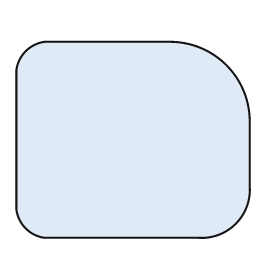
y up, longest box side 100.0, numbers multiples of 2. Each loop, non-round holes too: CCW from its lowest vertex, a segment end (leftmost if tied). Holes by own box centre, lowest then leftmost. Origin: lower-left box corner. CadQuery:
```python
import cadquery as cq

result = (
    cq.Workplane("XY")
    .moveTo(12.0, 0.0)
    .lineTo(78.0, 0.0)
    .threePointArc((94.0, 6.0), (100.0, 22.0))
    .lineTo(100.0, 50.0)
    .threePointArc((90.0, 74.0), (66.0, 84.0))
    .lineTo(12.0, 84.0)
    .threePointArc((4.0, 80.0), (0.0, 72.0))
    .lineTo(0.0, 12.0)
    .threePointArc((4.0, 4.0), (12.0, 0.0))
    .close()
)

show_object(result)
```